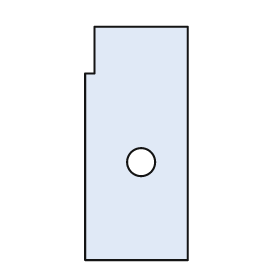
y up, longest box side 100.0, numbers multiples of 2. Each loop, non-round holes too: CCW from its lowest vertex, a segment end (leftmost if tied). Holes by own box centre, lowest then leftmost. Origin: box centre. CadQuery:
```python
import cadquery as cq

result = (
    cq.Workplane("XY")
    .moveTo(-22.0, -50.0)
    .lineTo(22.0, -50.0)
    .lineTo(22.0, 50.0)
    .lineTo(-18.0, 50.0)
    .lineTo(-18.0, 30.0)
    .lineTo(-22.0, 30.0)
    .close()
    .moveTo(2.0, -8.0)
    .circle(6.0)
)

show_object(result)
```